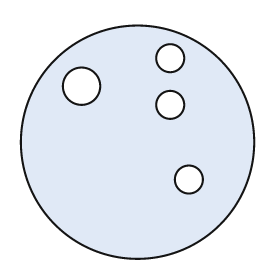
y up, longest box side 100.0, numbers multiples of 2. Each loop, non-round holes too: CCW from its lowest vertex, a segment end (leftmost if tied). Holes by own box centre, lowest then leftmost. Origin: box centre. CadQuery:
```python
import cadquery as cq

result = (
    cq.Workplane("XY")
    .moveTo(0.0, 0.0)
    .circle(50.0)
    .moveTo(22.0, -16.0)
    .circle(6.0)
    .moveTo(14.0, 16.0)
    .circle(6.0)
    .moveTo(-24.0, 24.0)
    .circle(8.0)
    .moveTo(14.0, 36.0)
    .circle(6.0)
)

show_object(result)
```